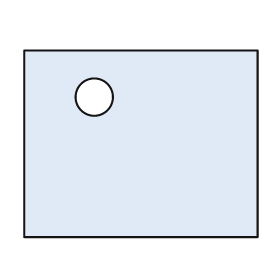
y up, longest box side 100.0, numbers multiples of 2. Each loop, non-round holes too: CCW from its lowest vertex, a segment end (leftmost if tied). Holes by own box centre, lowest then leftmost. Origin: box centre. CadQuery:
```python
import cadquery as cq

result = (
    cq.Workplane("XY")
    .moveTo(-50.0, -40.0)
    .lineTo(50.0, -40.0)
    .lineTo(50.0, 40.0)
    .lineTo(-50.0, 40.0)
    .close()
    .moveTo(-20.0, 20.0)
    .circle(8.0)
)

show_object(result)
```